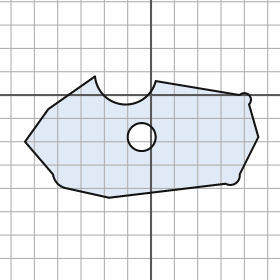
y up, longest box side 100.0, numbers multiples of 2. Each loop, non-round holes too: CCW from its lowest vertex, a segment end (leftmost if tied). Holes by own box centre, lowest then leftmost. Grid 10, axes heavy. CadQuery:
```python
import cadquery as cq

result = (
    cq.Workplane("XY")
    .moveTo(-18.0, -44.0)
    .lineTo(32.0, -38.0)
    .threePointArc((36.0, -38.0), (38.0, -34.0))
    .lineTo(46.0, -18.0)
    .lineTo(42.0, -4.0)
    .threePointArc((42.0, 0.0), (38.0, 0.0))
    .lineTo(2.0, 6.0)
    .threePointArc((-12.0, -4.0), (-24.0, 8.0))
    .lineTo(-44.0, -6.0)
    .lineTo(-54.0, -20.0)
    .lineTo(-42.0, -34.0)
    .threePointArc((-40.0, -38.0), (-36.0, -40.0))
    .close()
    .moveTo(-4.0, -18.0)
    .circle(6.0)
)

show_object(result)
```